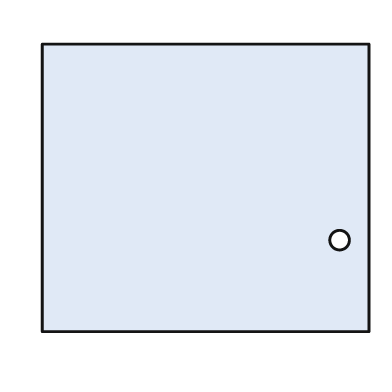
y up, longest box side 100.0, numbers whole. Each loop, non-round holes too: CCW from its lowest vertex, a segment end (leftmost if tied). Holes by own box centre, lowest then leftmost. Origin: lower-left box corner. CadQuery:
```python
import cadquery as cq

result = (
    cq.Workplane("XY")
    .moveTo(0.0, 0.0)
    .lineTo(100.0, 0.0)
    .lineTo(100.0, 88.0)
    .lineTo(0.0, 88.0)
    .close()
    .moveTo(91.0, 28.0)
    .circle(3.0)
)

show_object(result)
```